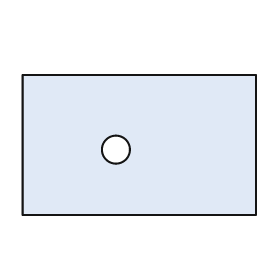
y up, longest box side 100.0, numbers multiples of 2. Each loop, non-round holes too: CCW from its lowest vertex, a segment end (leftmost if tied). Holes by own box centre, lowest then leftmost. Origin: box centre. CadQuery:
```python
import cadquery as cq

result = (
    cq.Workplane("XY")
    .moveTo(-50.0, -30.0)
    .lineTo(50.0, -30.0)
    .lineTo(50.0, 30.0)
    .lineTo(-50.0, 30.0)
    .close()
    .moveTo(-10.0, -2.0)
    .circle(6.0)
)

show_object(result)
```